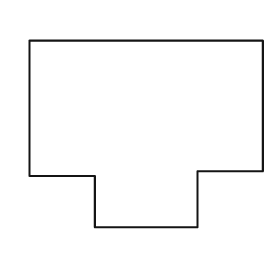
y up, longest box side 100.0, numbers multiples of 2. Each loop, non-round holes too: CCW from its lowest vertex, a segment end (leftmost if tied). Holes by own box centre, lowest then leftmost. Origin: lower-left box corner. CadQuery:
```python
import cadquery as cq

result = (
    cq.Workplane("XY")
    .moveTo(28.0, 0.0)
    .lineTo(72.0, 0.0)
    .lineTo(72.0, 24.0)
    .lineTo(100.0, 24.0)
    .lineTo(100.0, 80.0)
    .lineTo(0.0, 80.0)
    .lineTo(0.0, 22.0)
    .lineTo(28.0, 22.0)
    .close()
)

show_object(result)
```